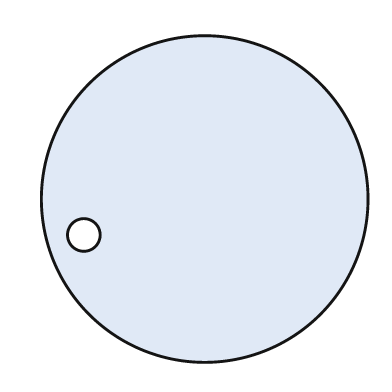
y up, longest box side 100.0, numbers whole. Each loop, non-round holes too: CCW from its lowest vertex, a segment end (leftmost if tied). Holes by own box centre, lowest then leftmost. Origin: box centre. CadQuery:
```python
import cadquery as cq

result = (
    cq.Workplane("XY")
    .moveTo(0.0, 0.0)
    .circle(50.0)
    .moveTo(-37.0, -11.0)
    .circle(5.0)
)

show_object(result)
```